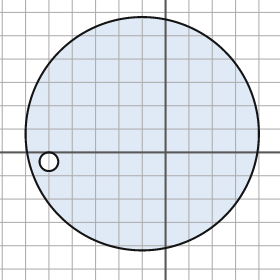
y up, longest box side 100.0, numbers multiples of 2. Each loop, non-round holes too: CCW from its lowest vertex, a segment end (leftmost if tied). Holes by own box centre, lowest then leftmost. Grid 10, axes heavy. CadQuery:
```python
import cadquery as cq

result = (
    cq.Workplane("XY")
    .moveTo(-10.0, 8.0)
    .circle(50.0)
    .moveTo(-50.0, -4.0)
    .circle(4.0)
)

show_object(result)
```